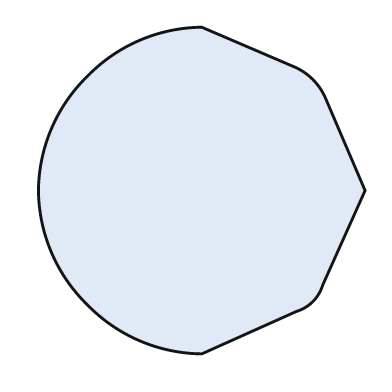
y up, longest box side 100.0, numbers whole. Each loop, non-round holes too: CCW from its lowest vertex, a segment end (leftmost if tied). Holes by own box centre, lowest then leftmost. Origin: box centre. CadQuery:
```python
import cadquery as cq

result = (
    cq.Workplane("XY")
    .moveTo(0.0, -50.0)
    .lineTo(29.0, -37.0)
    .threePointArc((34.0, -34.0), (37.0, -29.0))
    .lineTo(50.0, 0.0)
    .lineTo(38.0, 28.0)
    .threePointArc((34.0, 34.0), (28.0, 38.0))
    .lineTo(0.0, 50.0)
    .threePointArc((-19.0, 46.0), (-35.0, 35.0))
    .threePointArc((-46.0, 19.0), (-50.0, 0.0))
    .threePointArc((-46.0, -19.0), (-35.0, -35.0))
    .threePointArc((-19.0, -46.0), (0.0, -50.0))
    .close()
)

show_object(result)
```